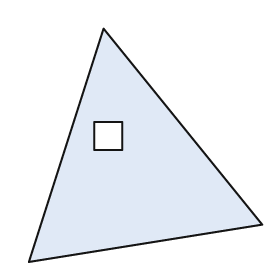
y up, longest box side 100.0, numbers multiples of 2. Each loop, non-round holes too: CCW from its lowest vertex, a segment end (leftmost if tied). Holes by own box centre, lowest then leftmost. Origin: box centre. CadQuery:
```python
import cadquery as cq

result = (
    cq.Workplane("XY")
    .moveTo(-50.0, -50.0)
    .lineTo(50.0, -34.0)
    .lineTo(-18.0, 50.0)
    .close()
    .moveTo(-22.0, -2.0)
    .lineTo(-10.0, -2.0)
    .lineTo(-10.0, 10.0)
    .lineTo(-22.0, 10.0)
    .close()
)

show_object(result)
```